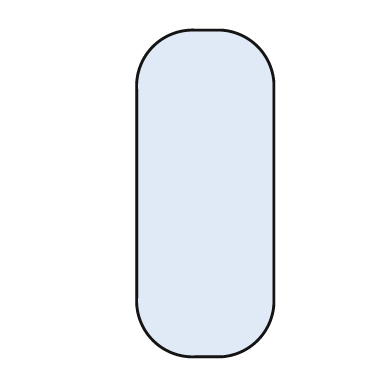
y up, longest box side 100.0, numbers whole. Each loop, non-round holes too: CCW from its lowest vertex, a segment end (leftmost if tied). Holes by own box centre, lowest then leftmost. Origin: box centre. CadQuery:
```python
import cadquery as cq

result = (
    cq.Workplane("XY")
    .moveTo(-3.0, -50.0)
    .lineTo(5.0, -50.0)
    .threePointArc((16.0, -45.0), (21.0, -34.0))
    .lineTo(21.0, 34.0)
    .threePointArc((16.0, 45.0), (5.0, 50.0))
    .lineTo(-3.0, 50.0)
    .threePointArc((-16.0, 45.0), (-21.0, 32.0))
    .lineTo(-21.0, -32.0)
    .threePointArc((-16.0, -45.0), (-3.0, -50.0))
    .close()
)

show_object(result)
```